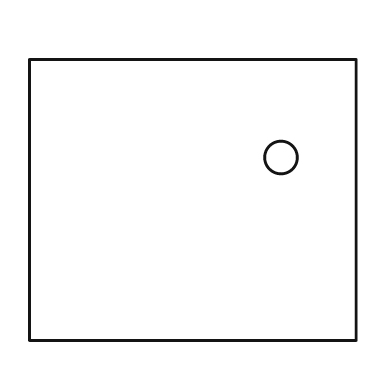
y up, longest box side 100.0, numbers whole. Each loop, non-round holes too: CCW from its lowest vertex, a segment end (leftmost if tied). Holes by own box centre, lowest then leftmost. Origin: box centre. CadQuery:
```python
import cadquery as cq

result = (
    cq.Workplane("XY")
    .moveTo(-50.0, -43.0)
    .lineTo(50.0, -43.0)
    .lineTo(50.0, 43.0)
    .lineTo(-50.0, 43.0)
    .close()
    .moveTo(27.0, 13.0)
    .circle(5.0)
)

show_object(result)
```